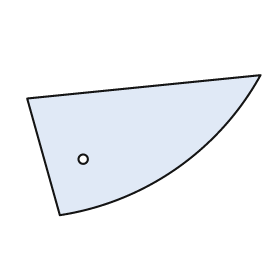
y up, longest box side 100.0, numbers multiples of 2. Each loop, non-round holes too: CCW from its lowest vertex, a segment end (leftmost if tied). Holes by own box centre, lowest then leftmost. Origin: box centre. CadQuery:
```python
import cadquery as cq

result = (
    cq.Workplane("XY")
    .moveTo(-36.0, -30.0)
    .threePointArc((14.0, -10.0), (50.0, 30.0))
    .lineTo(-50.0, 20.0)
    .close()
    .moveTo(-26.0, -6.0)
    .circle(2.0)
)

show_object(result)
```